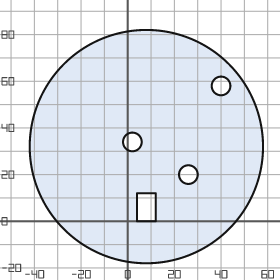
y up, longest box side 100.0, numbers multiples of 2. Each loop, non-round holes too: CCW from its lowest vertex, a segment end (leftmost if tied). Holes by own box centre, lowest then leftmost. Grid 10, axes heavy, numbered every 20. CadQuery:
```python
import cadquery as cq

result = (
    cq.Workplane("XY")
    .moveTo(8.0, 32.0)
    .circle(50.0)
    .moveTo(4.0, 0.0)
    .lineTo(12.0, 0.0)
    .lineTo(12.0, 12.0)
    .lineTo(4.0, 12.0)
    .close()
    .moveTo(26.0, 20.0)
    .circle(4.0)
    .moveTo(2.0, 34.0)
    .circle(4.0)
    .moveTo(40.0, 58.0)
    .circle(4.0)
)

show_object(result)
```